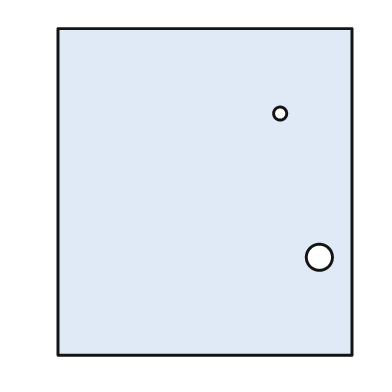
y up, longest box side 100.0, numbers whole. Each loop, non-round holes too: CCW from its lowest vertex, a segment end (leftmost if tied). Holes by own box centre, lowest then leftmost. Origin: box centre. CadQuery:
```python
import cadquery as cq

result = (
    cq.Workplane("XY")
    .moveTo(-45.0, -50.0)
    .lineTo(45.0, -50.0)
    .lineTo(45.0, 50.0)
    .lineTo(-45.0, 50.0)
    .close()
    .moveTo(35.0, -20.0)
    .circle(4.0)
    .moveTo(23.0, 24.0)
    .circle(2.0)
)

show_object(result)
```